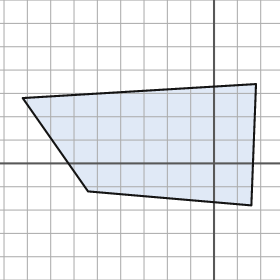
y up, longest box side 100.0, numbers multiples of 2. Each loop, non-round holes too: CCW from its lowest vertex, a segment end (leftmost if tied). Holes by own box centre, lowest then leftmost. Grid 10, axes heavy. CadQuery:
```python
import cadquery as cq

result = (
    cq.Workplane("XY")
    .moveTo(16.0, -18.0)
    .lineTo(18.0, 34.0)
    .lineTo(-82.0, 28.0)
    .lineTo(-54.0, -12.0)
    .close()
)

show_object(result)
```